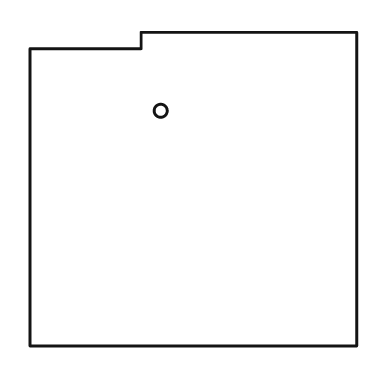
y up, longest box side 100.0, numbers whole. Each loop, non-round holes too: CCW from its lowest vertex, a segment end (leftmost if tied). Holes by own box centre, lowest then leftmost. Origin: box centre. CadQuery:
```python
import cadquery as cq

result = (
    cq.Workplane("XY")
    .moveTo(-50.0, -48.0)
    .lineTo(50.0, -48.0)
    .lineTo(50.0, 48.0)
    .lineTo(-16.0, 48.0)
    .lineTo(-16.0, 43.0)
    .lineTo(-50.0, 43.0)
    .close()
    .moveTo(-10.0, 24.0)
    .circle(2.0)
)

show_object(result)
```